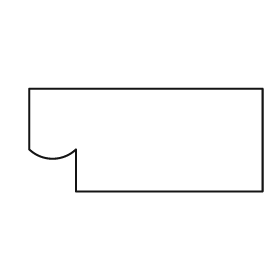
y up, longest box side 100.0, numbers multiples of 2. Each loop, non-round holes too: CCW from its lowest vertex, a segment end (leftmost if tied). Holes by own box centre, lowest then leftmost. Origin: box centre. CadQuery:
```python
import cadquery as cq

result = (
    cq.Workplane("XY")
    .moveTo(-30.0, -22.0)
    .lineTo(50.0, -22.0)
    .lineTo(50.0, 22.0)
    .lineTo(-50.0, 22.0)
    .lineTo(-50.0, -4.0)
    .threePointArc((-40.0, -8.0), (-30.0, -4.0))
    .close()
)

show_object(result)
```